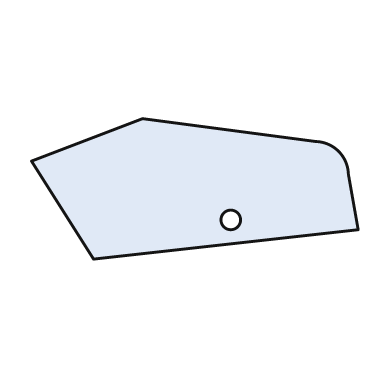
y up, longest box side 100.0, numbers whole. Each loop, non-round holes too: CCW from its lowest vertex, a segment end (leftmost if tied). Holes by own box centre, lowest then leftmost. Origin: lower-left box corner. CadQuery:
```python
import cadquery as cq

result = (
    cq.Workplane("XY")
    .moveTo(19.0, 0.0)
    .lineTo(100.0, 9.0)
    .lineTo(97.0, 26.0)
    .threePointArc((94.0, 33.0), (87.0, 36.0))
    .lineTo(34.0, 43.0)
    .lineTo(0.0, 30.0)
    .close()
    .moveTo(61.0, 12.0)
    .circle(3.0)
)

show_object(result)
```